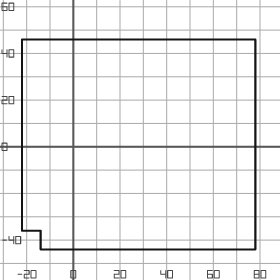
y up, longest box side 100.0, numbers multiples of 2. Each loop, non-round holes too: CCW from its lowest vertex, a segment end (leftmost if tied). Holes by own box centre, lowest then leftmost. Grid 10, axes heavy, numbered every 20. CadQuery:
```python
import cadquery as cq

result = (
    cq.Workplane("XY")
    .moveTo(-14.0, -44.0)
    .lineTo(78.0, -44.0)
    .lineTo(78.0, 46.0)
    .lineTo(-22.0, 46.0)
    .lineTo(-22.0, -36.0)
    .lineTo(-14.0, -36.0)
    .close()
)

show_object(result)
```